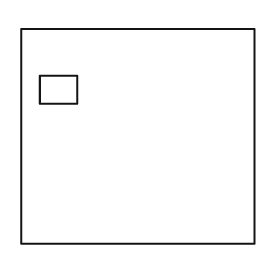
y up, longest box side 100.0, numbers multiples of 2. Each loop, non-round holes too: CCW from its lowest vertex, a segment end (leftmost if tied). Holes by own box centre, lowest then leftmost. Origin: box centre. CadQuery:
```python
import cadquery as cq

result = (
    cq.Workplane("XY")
    .moveTo(-50.0, -46.0)
    .lineTo(50.0, -46.0)
    .lineTo(50.0, 46.0)
    .lineTo(-50.0, 46.0)
    .close()
    .moveTo(-42.0, 14.0)
    .lineTo(-26.0, 14.0)
    .lineTo(-26.0, 26.0)
    .lineTo(-42.0, 26.0)
    .close()
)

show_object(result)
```